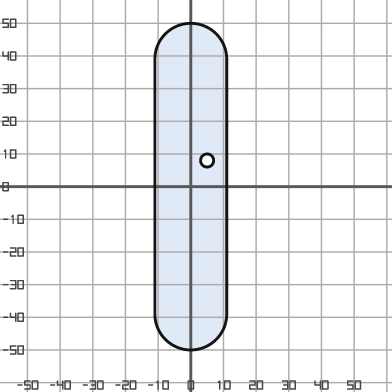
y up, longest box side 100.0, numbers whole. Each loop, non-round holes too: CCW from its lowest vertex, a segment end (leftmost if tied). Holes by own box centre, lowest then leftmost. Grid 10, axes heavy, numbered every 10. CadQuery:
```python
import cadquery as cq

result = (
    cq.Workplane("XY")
    .moveTo(-11.0, -39.0)
    .threePointArc((0.0, -50.0), (11.0, -39.0))
    .lineTo(11.0, 39.0)
    .threePointArc((0.0, 50.0), (-11.0, 39.0))
    .close()
    .moveTo(5.0, 8.0)
    .circle(2.0)
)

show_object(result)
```